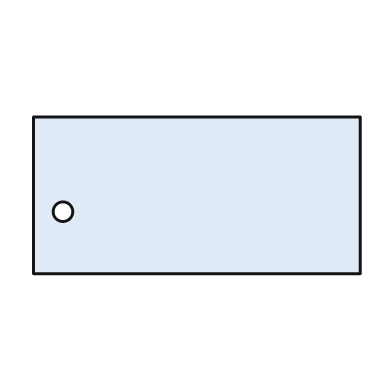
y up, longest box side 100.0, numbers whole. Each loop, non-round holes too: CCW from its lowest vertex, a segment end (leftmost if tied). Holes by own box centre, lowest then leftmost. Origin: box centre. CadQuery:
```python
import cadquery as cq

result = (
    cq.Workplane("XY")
    .moveTo(-50.0, -24.0)
    .lineTo(50.0, -24.0)
    .lineTo(50.0, 24.0)
    .lineTo(-50.0, 24.0)
    .close()
    .moveTo(-41.0, -5.0)
    .circle(3.0)
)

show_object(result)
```